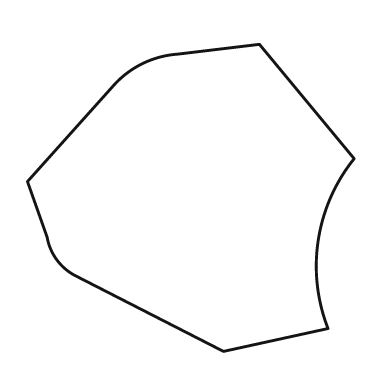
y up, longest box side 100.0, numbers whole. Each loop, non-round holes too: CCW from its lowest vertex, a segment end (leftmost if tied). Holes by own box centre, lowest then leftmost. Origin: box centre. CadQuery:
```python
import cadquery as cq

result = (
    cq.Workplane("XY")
    .moveTo(10.0, -47.0)
    .lineTo(42.0, -40.0)
    .threePointArc((39.0, -13.0), (50.0, 12.0))
    .lineTo(21.0, 47.0)
    .lineTo(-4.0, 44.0)
    .threePointArc((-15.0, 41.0), (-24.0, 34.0))
    .lineTo(-50.0, 5.0)
    .lineTo(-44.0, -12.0)
    .threePointArc((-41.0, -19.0), (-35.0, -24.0))
    .close()
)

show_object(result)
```